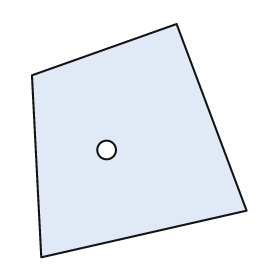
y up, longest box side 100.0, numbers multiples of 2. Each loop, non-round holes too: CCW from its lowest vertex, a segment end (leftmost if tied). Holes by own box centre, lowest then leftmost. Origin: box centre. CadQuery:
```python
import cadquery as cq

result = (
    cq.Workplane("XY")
    .moveTo(-42.0, -50.0)
    .lineTo(46.0, -30.0)
    .lineTo(16.0, 50.0)
    .lineTo(-46.0, 28.0)
    .close()
    .moveTo(-14.0, -4.0)
    .circle(4.0)
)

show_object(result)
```